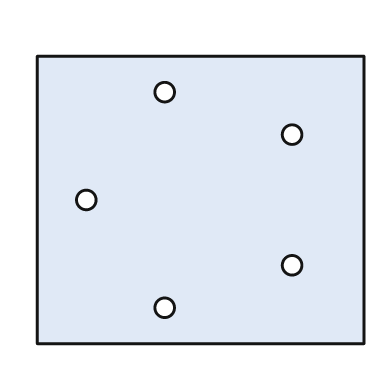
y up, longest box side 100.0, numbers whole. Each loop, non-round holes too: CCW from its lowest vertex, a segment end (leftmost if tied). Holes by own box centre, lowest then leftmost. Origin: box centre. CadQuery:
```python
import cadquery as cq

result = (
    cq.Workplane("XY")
    .moveTo(-50.0, -44.0)
    .lineTo(50.0, -44.0)
    .lineTo(50.0, 44.0)
    .lineTo(-50.0, 44.0)
    .close()
    .moveTo(-11.0, -33.0)
    .circle(3.0)
    .moveTo(28.0, -20.0)
    .circle(3.0)
    .moveTo(-35.0, 0.0)
    .circle(3.0)
    .moveTo(28.0, 20.0)
    .circle(3.0)
    .moveTo(-11.0, 33.0)
    .circle(3.0)
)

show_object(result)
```